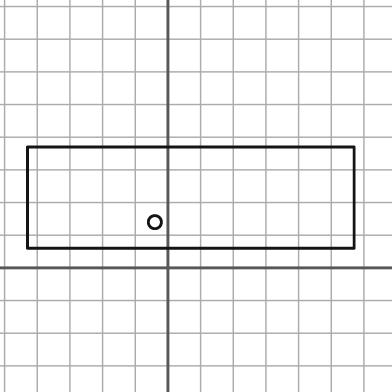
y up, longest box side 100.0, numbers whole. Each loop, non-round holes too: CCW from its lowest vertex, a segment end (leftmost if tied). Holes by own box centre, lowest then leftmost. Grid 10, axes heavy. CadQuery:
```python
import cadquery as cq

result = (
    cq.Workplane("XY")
    .moveTo(-43.0, 6.0)
    .lineTo(57.0, 6.0)
    .lineTo(57.0, 37.0)
    .lineTo(-43.0, 37.0)
    .close()
    .moveTo(-4.0, 14.0)
    .circle(2.0)
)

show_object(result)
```